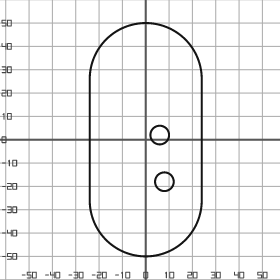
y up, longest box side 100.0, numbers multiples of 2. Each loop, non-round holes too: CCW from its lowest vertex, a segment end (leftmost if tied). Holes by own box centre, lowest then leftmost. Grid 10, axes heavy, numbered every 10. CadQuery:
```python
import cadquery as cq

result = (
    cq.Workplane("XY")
    .moveTo(-24.0, -26.0)
    .threePointArc((0.0, -50.0), (24.0, -26.0))
    .lineTo(24.0, 26.0)
    .threePointArc((0.0, 50.0), (-24.0, 26.0))
    .close()
    .moveTo(8.0, -18.0)
    .circle(4.0)
    .moveTo(6.0, 2.0)
    .circle(4.0)
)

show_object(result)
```